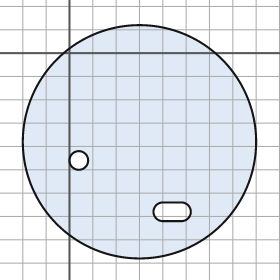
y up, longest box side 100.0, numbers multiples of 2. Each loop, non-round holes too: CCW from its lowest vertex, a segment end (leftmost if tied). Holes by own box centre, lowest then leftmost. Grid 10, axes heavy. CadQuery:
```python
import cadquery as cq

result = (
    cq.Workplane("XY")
    .moveTo(30.0, -38.0)
    .circle(50.0)
    .moveTo(40.0, -72.0)
    .lineTo(48.0, -72.0)
    .threePointArc((52.0, -68.0), (48.0, -64.0))
    .lineTo(40.0, -64.0)
    .threePointArc((36.0, -68.0), (40.0, -72.0))
    .close()
    .moveTo(4.0, -46.0)
    .circle(4.0)
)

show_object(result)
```